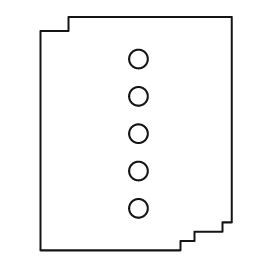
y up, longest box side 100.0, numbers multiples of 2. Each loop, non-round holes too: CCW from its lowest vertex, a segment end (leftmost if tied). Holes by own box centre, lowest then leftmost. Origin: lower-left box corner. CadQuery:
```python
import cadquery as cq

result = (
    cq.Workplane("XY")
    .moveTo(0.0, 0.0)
    .lineTo(60.0, 0.0)
    .lineTo(60.0, 4.0)
    .lineTo(66.0, 4.0)
    .lineTo(66.0, 8.0)
    .lineTo(78.0, 8.0)
    .lineTo(78.0, 12.0)
    .lineTo(82.0, 12.0)
    .lineTo(82.0, 100.0)
    .lineTo(12.0, 100.0)
    .lineTo(12.0, 94.0)
    .lineTo(0.0, 94.0)
    .close()
    .moveTo(42.0, 18.0)
    .circle(4.0)
    .moveTo(42.0, 34.0)
    .circle(4.0)
    .moveTo(42.0, 50.0)
    .circle(4.0)
    .moveTo(42.0, 66.0)
    .circle(4.0)
    .moveTo(42.0, 82.0)
    .circle(4.0)
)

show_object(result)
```